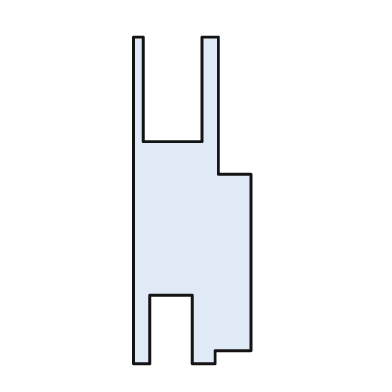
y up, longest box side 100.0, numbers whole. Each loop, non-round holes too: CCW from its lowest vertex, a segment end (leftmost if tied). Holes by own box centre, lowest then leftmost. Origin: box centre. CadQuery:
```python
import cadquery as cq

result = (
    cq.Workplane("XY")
    .moveTo(-18.0, -50.0)
    .lineTo(-13.0, -50.0)
    .lineTo(-13.0, -29.0)
    .lineTo(0.0, -29.0)
    .lineTo(0.0, -50.0)
    .lineTo(7.0, -50.0)
    .lineTo(7.0, -46.0)
    .lineTo(18.0, -46.0)
    .lineTo(18.0, 8.0)
    .lineTo(8.0, 8.0)
    .lineTo(8.0, 50.0)
    .lineTo(3.0, 50.0)
    .lineTo(3.0, 18.0)
    .lineTo(-15.0, 18.0)
    .lineTo(-15.0, 50.0)
    .lineTo(-18.0, 50.0)
    .close()
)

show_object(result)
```